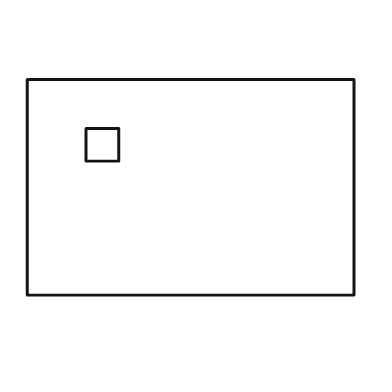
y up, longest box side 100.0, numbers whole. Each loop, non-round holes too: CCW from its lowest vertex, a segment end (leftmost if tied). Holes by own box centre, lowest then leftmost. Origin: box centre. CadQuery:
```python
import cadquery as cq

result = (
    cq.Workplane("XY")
    .moveTo(-50.0, -33.0)
    .lineTo(50.0, -33.0)
    .lineTo(50.0, 33.0)
    .lineTo(-50.0, 33.0)
    .close()
    .moveTo(-32.0, 8.0)
    .lineTo(-22.0, 8.0)
    .lineTo(-22.0, 18.0)
    .lineTo(-32.0, 18.0)
    .close()
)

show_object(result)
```